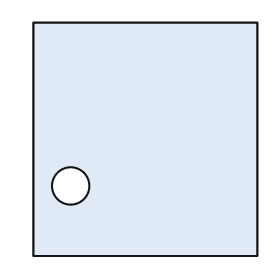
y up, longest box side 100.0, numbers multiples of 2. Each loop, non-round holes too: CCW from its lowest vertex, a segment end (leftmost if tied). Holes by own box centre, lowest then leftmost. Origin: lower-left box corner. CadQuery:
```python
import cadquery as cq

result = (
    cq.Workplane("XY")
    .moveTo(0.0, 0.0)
    .lineTo(96.0, 0.0)
    .lineTo(96.0, 100.0)
    .lineTo(0.0, 100.0)
    .close()
    .moveTo(16.0, 30.0)
    .circle(8.0)
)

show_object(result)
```